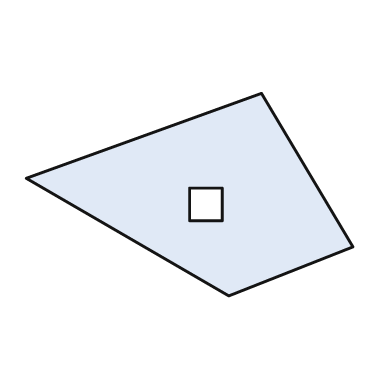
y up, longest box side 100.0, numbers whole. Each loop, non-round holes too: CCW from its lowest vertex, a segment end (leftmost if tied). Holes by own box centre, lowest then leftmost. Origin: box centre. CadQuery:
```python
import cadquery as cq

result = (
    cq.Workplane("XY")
    .moveTo(12.0, -31.0)
    .lineTo(50.0, -16.0)
    .lineTo(22.0, 31.0)
    .lineTo(-50.0, 5.0)
    .close()
    .moveTo(0.0, -8.0)
    .lineTo(10.0, -8.0)
    .lineTo(10.0, 2.0)
    .lineTo(0.0, 2.0)
    .close()
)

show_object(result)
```